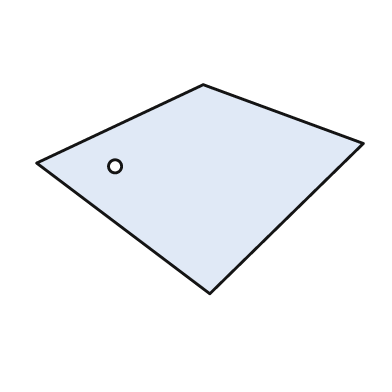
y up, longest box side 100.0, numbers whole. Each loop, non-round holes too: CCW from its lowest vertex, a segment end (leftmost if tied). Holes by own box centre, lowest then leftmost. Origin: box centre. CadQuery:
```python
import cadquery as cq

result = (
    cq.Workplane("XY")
    .moveTo(3.0, -32.0)
    .lineTo(50.0, 14.0)
    .lineTo(1.0, 32.0)
    .lineTo(-50.0, 8.0)
    .close()
    .moveTo(-26.0, 7.0)
    .circle(2.0)
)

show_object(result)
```